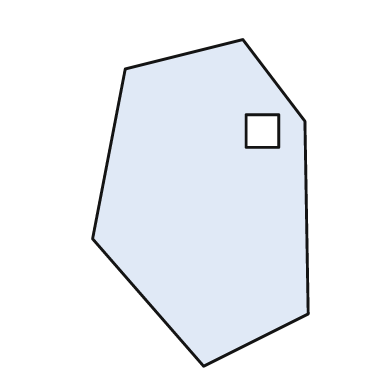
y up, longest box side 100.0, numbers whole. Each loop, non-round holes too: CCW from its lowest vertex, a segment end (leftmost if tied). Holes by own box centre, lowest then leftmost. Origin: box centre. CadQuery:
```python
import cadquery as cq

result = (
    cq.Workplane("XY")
    .moveTo(1.0, -50.0)
    .lineTo(33.0, -34.0)
    .lineTo(32.0, 25.0)
    .lineTo(13.0, 50.0)
    .lineTo(-23.0, 41.0)
    .lineTo(-33.0, -11.0)
    .close()
    .moveTo(14.0, 17.0)
    .lineTo(24.0, 17.0)
    .lineTo(24.0, 27.0)
    .lineTo(14.0, 27.0)
    .close()
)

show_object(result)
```